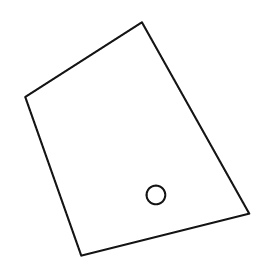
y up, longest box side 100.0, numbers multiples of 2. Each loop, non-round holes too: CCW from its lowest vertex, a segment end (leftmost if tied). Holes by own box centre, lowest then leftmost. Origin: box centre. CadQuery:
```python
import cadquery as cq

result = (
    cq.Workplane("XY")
    .moveTo(-24.0, -50.0)
    .lineTo(48.0, -32.0)
    .lineTo(2.0, 50.0)
    .lineTo(-48.0, 18.0)
    .close()
    .moveTo(8.0, -24.0)
    .circle(4.0)
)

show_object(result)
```